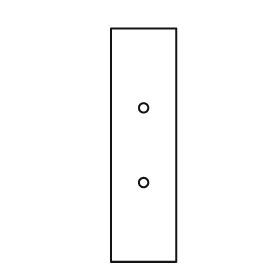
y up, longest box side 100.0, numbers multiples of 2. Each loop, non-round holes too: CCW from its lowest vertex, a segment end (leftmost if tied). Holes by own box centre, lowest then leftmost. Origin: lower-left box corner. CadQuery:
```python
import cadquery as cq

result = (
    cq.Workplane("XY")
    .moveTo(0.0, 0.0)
    .lineTo(28.0, 0.0)
    .lineTo(28.0, 100.0)
    .lineTo(0.0, 100.0)
    .close()
    .moveTo(14.0, 34.0)
    .circle(2.0)
    .moveTo(14.0, 66.0)
    .circle(2.0)
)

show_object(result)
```